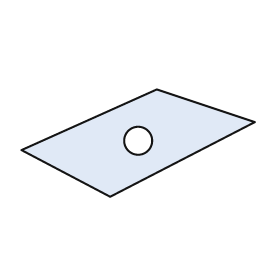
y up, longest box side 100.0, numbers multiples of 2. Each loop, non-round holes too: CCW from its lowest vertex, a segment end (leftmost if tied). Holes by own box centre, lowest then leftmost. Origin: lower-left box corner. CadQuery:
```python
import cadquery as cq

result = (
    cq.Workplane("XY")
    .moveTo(38.0, 0.0)
    .lineTo(100.0, 32.0)
    .lineTo(58.0, 46.0)
    .lineTo(0.0, 20.0)
    .close()
    .moveTo(50.0, 24.0)
    .circle(6.0)
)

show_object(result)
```